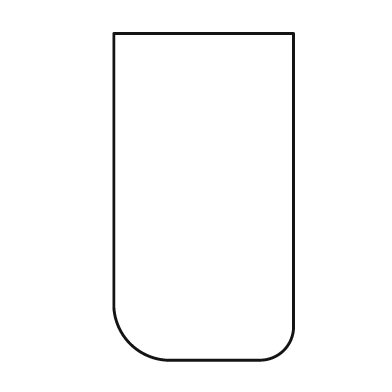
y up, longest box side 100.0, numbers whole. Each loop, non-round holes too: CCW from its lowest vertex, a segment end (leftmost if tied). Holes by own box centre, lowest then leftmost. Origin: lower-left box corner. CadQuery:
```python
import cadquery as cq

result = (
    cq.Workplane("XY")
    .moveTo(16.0, 0.0)
    .lineTo(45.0, 0.0)
    .threePointArc((52.0, 3.0), (55.0, 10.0))
    .lineTo(55.0, 100.0)
    .lineTo(0.0, 100.0)
    .lineTo(0.0, 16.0)
    .threePointArc((5.0, 5.0), (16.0, 0.0))
    .close()
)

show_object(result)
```